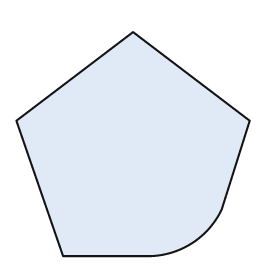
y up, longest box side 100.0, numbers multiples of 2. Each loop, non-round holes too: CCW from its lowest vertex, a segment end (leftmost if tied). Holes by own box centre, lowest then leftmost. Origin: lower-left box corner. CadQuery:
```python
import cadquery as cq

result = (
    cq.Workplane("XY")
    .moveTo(20.0, 0.0)
    .lineTo(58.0, 0.0)
    .threePointArc((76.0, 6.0), (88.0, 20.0))
    .lineTo(100.0, 58.0)
    .lineTo(50.0, 96.0)
    .lineTo(0.0, 58.0)
    .close()
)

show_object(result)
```